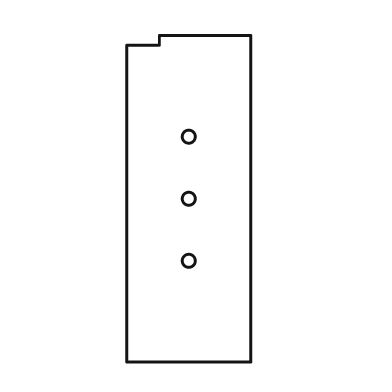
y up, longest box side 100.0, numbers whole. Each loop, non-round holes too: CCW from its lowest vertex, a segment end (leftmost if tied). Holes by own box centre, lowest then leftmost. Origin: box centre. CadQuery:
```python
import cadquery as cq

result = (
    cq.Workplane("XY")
    .moveTo(-19.0, -50.0)
    .lineTo(19.0, -50.0)
    .lineTo(19.0, 50.0)
    .lineTo(-9.0, 50.0)
    .lineTo(-9.0, 47.0)
    .lineTo(-19.0, 47.0)
    .close()
    .moveTo(0.0, -19.0)
    .circle(2.0)
    .moveTo(0.0, 0.0)
    .circle(2.0)
    .moveTo(0.0, 19.0)
    .circle(2.0)
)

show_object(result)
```